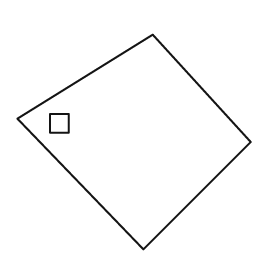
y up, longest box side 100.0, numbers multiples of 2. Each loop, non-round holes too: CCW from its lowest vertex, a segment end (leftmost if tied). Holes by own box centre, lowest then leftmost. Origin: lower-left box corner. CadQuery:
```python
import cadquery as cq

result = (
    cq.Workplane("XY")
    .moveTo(54.0, 0.0)
    .lineTo(100.0, 46.0)
    .lineTo(58.0, 92.0)
    .lineTo(0.0, 56.0)
    .close()
    .moveTo(14.0, 50.0)
    .lineTo(22.0, 50.0)
    .lineTo(22.0, 58.0)
    .lineTo(14.0, 58.0)
    .close()
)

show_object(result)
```